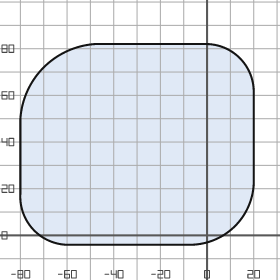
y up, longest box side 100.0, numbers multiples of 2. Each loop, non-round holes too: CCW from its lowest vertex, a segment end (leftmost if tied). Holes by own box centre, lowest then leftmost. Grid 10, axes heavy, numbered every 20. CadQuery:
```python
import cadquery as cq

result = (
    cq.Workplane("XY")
    .moveTo(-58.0, -4.0)
    .lineTo(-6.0, -4.0)
    .threePointArc((12.0, 4.0), (20.0, 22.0))
    .lineTo(20.0, 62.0)
    .threePointArc((14.0, 76.0), (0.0, 82.0))
    .lineTo(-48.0, 82.0)
    .threePointArc((-70.0, 72.0), (-80.0, 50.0))
    .lineTo(-80.0, 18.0)
    .threePointArc((-74.0, 2.0), (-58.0, -4.0))
    .close()
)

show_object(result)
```